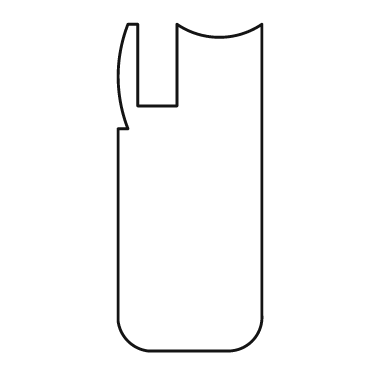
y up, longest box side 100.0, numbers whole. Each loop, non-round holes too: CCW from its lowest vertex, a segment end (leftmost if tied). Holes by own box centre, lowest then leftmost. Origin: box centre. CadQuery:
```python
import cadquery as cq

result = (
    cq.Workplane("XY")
    .moveTo(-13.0, -50.0)
    .lineTo(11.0, -50.0)
    .threePointArc((19.0, -47.0), (22.0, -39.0))
    .lineTo(22.0, 50.0)
    .threePointArc((9.0, 46.0), (-4.0, 50.0))
    .lineTo(-4.0, 25.0)
    .lineTo(-16.0, 25.0)
    .lineTo(-16.0, 50.0)
    .lineTo(-19.0, 50.0)
    .threePointArc((-22.0, 34.0), (-19.0, 18.0))
    .lineTo(-22.0, 18.0)
    .lineTo(-22.0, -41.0)
    .threePointArc((-19.0, -47.0), (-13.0, -50.0))
    .close()
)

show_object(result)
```